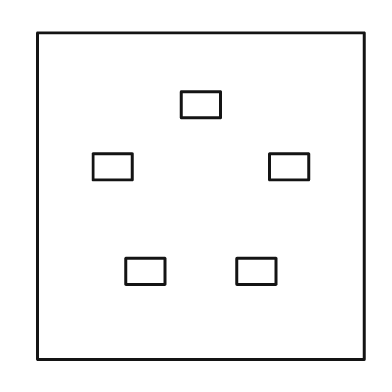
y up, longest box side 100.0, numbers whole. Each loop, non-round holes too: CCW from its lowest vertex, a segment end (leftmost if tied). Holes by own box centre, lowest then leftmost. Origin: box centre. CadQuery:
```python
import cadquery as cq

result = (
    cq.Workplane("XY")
    .moveTo(-50.0, -50.0)
    .lineTo(50.0, -50.0)
    .lineTo(50.0, 50.0)
    .lineTo(-50.0, 50.0)
    .close()
    .moveTo(-23.0, -27.0)
    .lineTo(-11.0, -27.0)
    .lineTo(-11.0, -19.0)
    .lineTo(-23.0, -19.0)
    .close()
    .moveTo(11.0, -27.0)
    .lineTo(23.0, -27.0)
    .lineTo(23.0, -19.0)
    .lineTo(11.0, -19.0)
    .close()
    .moveTo(-33.0, 5.0)
    .lineTo(-21.0, 5.0)
    .lineTo(-21.0, 13.0)
    .lineTo(-33.0, 13.0)
    .close()
    .moveTo(21.0, 5.0)
    .lineTo(33.0, 5.0)
    .lineTo(33.0, 13.0)
    .lineTo(21.0, 13.0)
    .close()
    .moveTo(-6.0, 24.0)
    .lineTo(6.0, 24.0)
    .lineTo(6.0, 32.0)
    .lineTo(-6.0, 32.0)
    .close()
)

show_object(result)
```